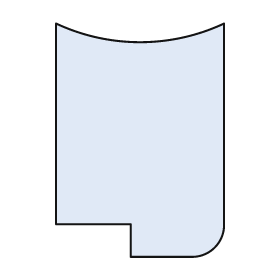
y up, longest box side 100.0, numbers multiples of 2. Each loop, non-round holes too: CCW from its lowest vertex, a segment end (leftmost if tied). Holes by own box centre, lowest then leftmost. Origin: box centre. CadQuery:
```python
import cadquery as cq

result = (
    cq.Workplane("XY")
    .moveTo(-4.0, -50.0)
    .lineTo(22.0, -50.0)
    .threePointArc((32.0, -46.0), (36.0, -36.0))
    .lineTo(36.0, 50.0)
    .threePointArc((0.0, 42.0), (-36.0, 50.0))
    .lineTo(-36.0, -36.0)
    .lineTo(-4.0, -36.0)
    .close()
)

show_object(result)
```